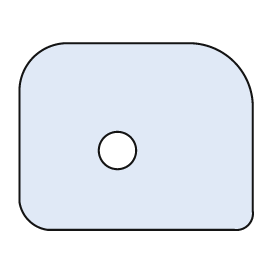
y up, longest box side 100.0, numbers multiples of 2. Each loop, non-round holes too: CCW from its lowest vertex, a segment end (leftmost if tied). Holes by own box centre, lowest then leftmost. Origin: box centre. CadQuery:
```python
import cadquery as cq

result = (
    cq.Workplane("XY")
    .moveTo(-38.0, -40.0)
    .lineTo(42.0, -40.0)
    .threePointArc((48.0, -38.0), (50.0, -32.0))
    .lineTo(50.0, 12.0)
    .threePointArc((42.0, 32.0), (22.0, 40.0))
    .lineTo(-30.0, 40.0)
    .threePointArc((-44.0, 34.0), (-50.0, 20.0))
    .lineTo(-50.0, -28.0)
    .threePointArc((-46.0, -36.0), (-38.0, -40.0))
    .close()
    .moveTo(-8.0, -6.0)
    .circle(8.0)
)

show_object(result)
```